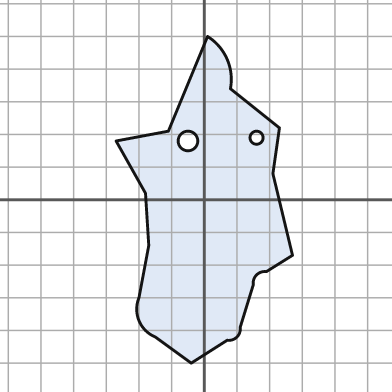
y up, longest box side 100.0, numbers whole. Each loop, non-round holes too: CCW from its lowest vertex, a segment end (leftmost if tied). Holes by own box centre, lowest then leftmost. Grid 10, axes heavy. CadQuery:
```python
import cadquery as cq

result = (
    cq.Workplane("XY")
    .moveTo(-4.0, -50.0)
    .lineTo(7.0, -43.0)
    .threePointArc((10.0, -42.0), (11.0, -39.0))
    .lineTo(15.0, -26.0)
    .threePointArc((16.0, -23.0), (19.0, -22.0))
    .lineTo(27.0, -17.0)
    .lineTo(21.0, 8.0)
    .lineTo(23.0, 22.0)
    .lineTo(8.0, 34.0)
    .threePointArc((7.0, 43.0), (1.0, 50.0))
    .lineTo(-11.0, 21.0)
    .lineTo(-27.0, 18.0)
    .lineTo(-18.0, 2.0)
    .lineTo(-17.0, -14.0)
    .lineTo(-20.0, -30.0)
    .threePointArc((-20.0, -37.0), (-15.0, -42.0))
    .close()
    .moveTo(-5.0, 18.0)
    .circle(3.0)
    .moveTo(16.0, 19.0)
    .circle(2.0)
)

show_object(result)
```